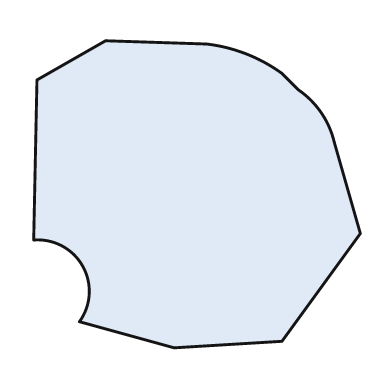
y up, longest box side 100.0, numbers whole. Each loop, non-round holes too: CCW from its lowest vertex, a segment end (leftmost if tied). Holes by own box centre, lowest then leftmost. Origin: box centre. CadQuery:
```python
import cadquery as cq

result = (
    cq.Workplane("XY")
    .moveTo(-7.0, -47.0)
    .lineTo(26.0, -45.0)
    .lineTo(50.0, -12.0)
    .lineTo(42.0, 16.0)
    .threePointArc((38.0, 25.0), (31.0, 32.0))
    .lineTo(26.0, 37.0)
    .threePointArc((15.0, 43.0), (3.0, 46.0))
    .lineTo(-28.0, 47.0)
    .lineTo(-49.0, 35.0)
    .lineTo(-50.0, -14.0)
    .threePointArc((-35.0, -22.0), (-36.0, -39.0))
    .close()
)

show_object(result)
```